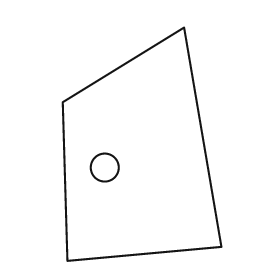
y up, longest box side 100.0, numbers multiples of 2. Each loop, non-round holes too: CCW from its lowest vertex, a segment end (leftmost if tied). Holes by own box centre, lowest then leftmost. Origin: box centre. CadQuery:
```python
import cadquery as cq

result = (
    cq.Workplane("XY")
    .moveTo(-32.0, -50.0)
    .lineTo(34.0, -44.0)
    .lineTo(18.0, 50.0)
    .lineTo(-34.0, 18.0)
    .close()
    .moveTo(-16.0, -10.0)
    .circle(6.0)
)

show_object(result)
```